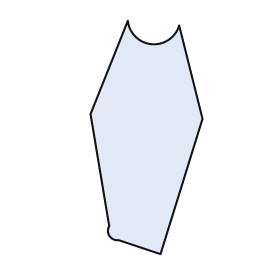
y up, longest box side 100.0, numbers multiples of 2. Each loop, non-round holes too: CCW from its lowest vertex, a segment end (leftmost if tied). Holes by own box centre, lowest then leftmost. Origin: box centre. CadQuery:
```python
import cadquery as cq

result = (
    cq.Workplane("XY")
    .moveTo(6.0, -50.0)
    .lineTo(24.0, 8.0)
    .lineTo(14.0, 48.0)
    .threePointArc((2.0, 40.0), (-8.0, 50.0))
    .lineTo(-24.0, 10.0)
    .lineTo(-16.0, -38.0)
    .threePointArc((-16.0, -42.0), (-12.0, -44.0))
    .close()
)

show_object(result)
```